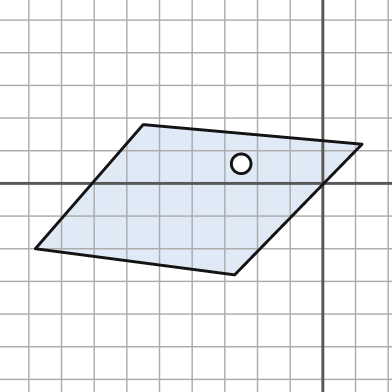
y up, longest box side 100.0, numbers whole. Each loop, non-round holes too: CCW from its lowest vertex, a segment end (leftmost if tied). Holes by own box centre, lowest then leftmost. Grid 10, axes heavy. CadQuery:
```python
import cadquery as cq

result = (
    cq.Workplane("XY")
    .moveTo(-27.0, -28.0)
    .lineTo(12.0, 12.0)
    .lineTo(-55.0, 18.0)
    .lineTo(-88.0, -20.0)
    .close()
    .moveTo(-25.0, 6.0)
    .circle(3.0)
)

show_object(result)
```